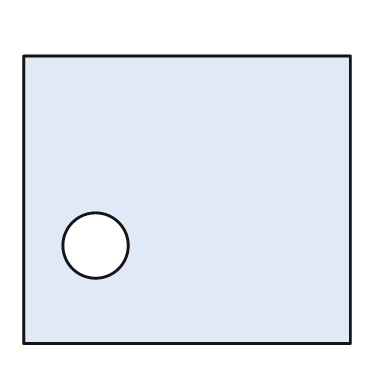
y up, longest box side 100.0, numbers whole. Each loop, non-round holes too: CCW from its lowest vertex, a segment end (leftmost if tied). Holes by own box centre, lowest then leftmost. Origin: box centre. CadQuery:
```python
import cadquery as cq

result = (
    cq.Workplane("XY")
    .moveTo(-50.0, -44.0)
    .lineTo(50.0, -44.0)
    .lineTo(50.0, 44.0)
    .lineTo(-50.0, 44.0)
    .close()
    .moveTo(-28.0, -14.0)
    .circle(10.0)
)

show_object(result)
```